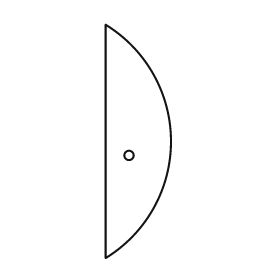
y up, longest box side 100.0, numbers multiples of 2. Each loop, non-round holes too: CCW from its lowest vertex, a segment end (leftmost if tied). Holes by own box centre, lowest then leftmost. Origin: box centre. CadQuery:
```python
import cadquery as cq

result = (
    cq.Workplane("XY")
    .moveTo(-14.0, -50.0)
    .threePointArc((14.0, 0.0), (-14.0, 50.0))
    .close()
    .moveTo(-4.0, -6.0)
    .circle(2.0)
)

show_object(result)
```